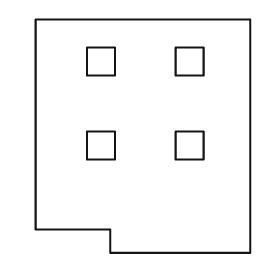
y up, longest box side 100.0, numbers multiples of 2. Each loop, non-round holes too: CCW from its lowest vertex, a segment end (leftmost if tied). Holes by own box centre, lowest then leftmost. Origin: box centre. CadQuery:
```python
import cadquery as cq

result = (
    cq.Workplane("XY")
    .moveTo(-14.0, -50.0)
    .lineTo(46.0, -50.0)
    .lineTo(46.0, 50.0)
    .lineTo(-46.0, 50.0)
    .lineTo(-46.0, -40.0)
    .lineTo(-14.0, -40.0)
    .close()
    .moveTo(-24.0, -10.0)
    .lineTo(-12.0, -10.0)
    .lineTo(-12.0, 2.0)
    .lineTo(-24.0, 2.0)
    .close()
    .moveTo(14.0, -10.0)
    .lineTo(26.0, -10.0)
    .lineTo(26.0, 2.0)
    .lineTo(14.0, 2.0)
    .close()
    .moveTo(-24.0, 26.0)
    .lineTo(-12.0, 26.0)
    .lineTo(-12.0, 38.0)
    .lineTo(-24.0, 38.0)
    .close()
    .moveTo(14.0, 26.0)
    .lineTo(26.0, 26.0)
    .lineTo(26.0, 38.0)
    .lineTo(14.0, 38.0)
    .close()
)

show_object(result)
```